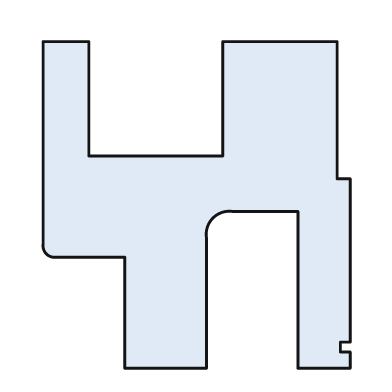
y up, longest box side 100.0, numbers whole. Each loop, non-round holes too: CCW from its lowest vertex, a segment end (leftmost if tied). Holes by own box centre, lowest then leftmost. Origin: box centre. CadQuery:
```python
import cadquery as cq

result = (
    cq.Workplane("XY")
    .moveTo(-22.0, -50.0)
    .lineTo(3.0, -50.0)
    .lineTo(3.0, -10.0)
    .threePointArc((5.0, -4.0), (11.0, -2.0))
    .lineTo(31.0, -2.0)
    .lineTo(31.0, -50.0)
    .lineTo(47.0, -50.0)
    .lineTo(47.0, -45.0)
    .lineTo(44.0, -45.0)
    .lineTo(44.0, -42.0)
    .lineTo(47.0, -42.0)
    .lineTo(47.0, 8.0)
    .lineTo(43.0, 8.0)
    .lineTo(43.0, 50.0)
    .lineTo(8.0, 50.0)
    .lineTo(8.0, 15.0)
    .lineTo(-33.0, 15.0)
    .lineTo(-33.0, 50.0)
    .lineTo(-47.0, 50.0)
    .lineTo(-47.0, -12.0)
    .threePointArc((-46.0, -15.0), (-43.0, -16.0))
    .lineTo(-22.0, -16.0)
    .close()
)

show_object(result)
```